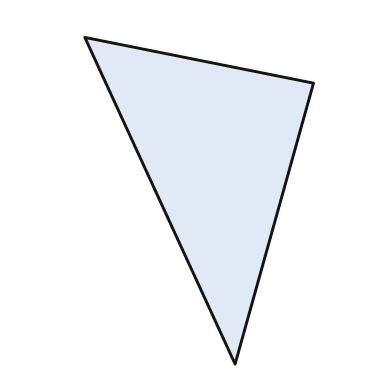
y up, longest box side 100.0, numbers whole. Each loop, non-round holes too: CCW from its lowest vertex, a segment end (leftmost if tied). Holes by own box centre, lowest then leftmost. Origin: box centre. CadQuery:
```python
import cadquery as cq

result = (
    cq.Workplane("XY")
    .moveTo(11.0, -50.0)
    .lineTo(35.0, 36.0)
    .lineTo(-35.0, 50.0)
    .close()
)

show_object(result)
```